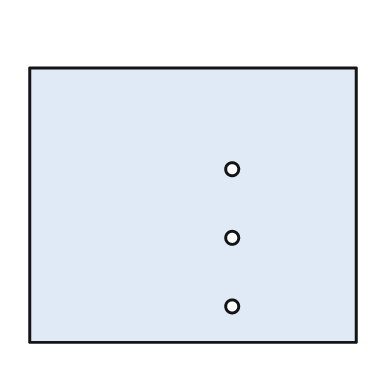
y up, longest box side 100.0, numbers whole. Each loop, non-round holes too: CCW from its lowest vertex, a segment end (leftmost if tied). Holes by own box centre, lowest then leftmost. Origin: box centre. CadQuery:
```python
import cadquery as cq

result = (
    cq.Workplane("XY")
    .moveTo(-50.0, -42.0)
    .lineTo(50.0, -42.0)
    .lineTo(50.0, 42.0)
    .lineTo(-50.0, 42.0)
    .close()
    .moveTo(12.0, -31.0)
    .circle(2.0)
    .moveTo(12.0, -10.0)
    .circle(2.0)
    .moveTo(12.0, 11.0)
    .circle(2.0)
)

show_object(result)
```